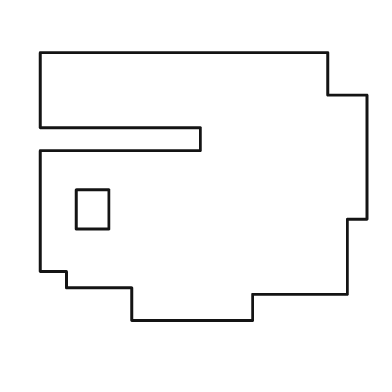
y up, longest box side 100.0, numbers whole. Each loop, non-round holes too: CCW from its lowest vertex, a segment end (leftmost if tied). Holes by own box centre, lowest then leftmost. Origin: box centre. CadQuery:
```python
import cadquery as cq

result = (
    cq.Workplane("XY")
    .moveTo(-22.0, -41.0)
    .lineTo(15.0, -41.0)
    .lineTo(15.0, -33.0)
    .lineTo(44.0, -33.0)
    .lineTo(44.0, -10.0)
    .lineTo(50.0, -10.0)
    .lineTo(50.0, 28.0)
    .lineTo(38.0, 28.0)
    .lineTo(38.0, 41.0)
    .lineTo(-50.0, 41.0)
    .lineTo(-50.0, 18.0)
    .lineTo(-1.0, 18.0)
    .lineTo(-1.0, 11.0)
    .lineTo(-50.0, 11.0)
    .lineTo(-50.0, -26.0)
    .lineTo(-42.0, -26.0)
    .lineTo(-42.0, -31.0)
    .lineTo(-22.0, -31.0)
    .close()
    .moveTo(-39.0, -13.0)
    .lineTo(-29.0, -13.0)
    .lineTo(-29.0, -1.0)
    .lineTo(-39.0, -1.0)
    .close()
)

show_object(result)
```